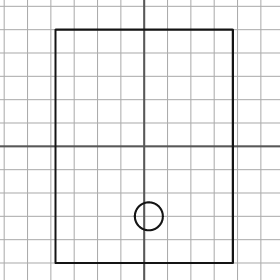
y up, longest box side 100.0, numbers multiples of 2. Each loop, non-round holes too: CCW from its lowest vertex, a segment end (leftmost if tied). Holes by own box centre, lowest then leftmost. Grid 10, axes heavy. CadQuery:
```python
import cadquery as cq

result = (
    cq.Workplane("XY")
    .moveTo(-38.0, -50.0)
    .lineTo(38.0, -50.0)
    .lineTo(38.0, 50.0)
    .lineTo(-38.0, 50.0)
    .close()
    .moveTo(2.0, -30.0)
    .circle(6.0)
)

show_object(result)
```